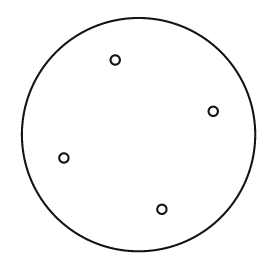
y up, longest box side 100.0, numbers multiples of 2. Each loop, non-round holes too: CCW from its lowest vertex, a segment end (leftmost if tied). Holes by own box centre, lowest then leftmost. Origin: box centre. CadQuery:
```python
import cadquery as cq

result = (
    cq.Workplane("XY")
    .moveTo(0.0, 0.0)
    .circle(50.0)
    .moveTo(10.0, -32.0)
    .circle(2.0)
    .moveTo(-32.0, -10.0)
    .circle(2.0)
    .moveTo(32.0, 10.0)
    .circle(2.0)
    .moveTo(-10.0, 32.0)
    .circle(2.0)
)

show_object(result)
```